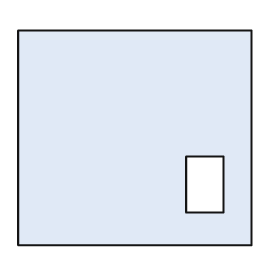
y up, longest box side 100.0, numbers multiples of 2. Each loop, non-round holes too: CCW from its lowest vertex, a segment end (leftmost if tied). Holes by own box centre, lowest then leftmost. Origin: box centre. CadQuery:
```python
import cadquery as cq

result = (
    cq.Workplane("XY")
    .moveTo(-50.0, -46.0)
    .lineTo(50.0, -46.0)
    .lineTo(50.0, 46.0)
    .lineTo(-50.0, 46.0)
    .close()
    .moveTo(22.0, -32.0)
    .lineTo(38.0, -32.0)
    .lineTo(38.0, -8.0)
    .lineTo(22.0, -8.0)
    .close()
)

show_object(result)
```